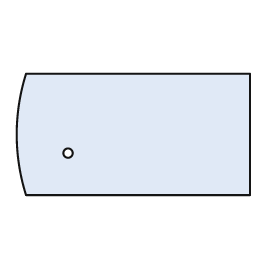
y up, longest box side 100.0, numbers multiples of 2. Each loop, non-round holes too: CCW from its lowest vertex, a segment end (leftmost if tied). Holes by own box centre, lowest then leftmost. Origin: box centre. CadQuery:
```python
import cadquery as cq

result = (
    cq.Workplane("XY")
    .moveTo(-46.0, -26.0)
    .lineTo(50.0, -26.0)
    .lineTo(50.0, 26.0)
    .lineTo(-46.0, 26.0)
    .threePointArc((-50.0, 0.0), (-46.0, -26.0))
    .close()
    .moveTo(-28.0, -8.0)
    .circle(2.0)
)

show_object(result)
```